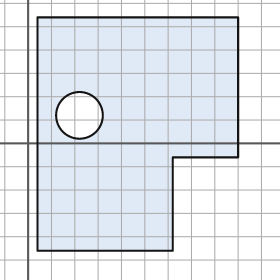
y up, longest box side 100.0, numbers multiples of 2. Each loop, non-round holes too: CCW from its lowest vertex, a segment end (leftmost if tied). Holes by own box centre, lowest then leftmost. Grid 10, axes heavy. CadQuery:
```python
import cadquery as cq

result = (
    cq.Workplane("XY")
    .moveTo(4.0, -46.0)
    .lineTo(62.0, -46.0)
    .lineTo(62.0, -6.0)
    .lineTo(90.0, -6.0)
    .lineTo(90.0, 54.0)
    .lineTo(4.0, 54.0)
    .close()
    .moveTo(22.0, 12.0)
    .circle(10.0)
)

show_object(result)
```